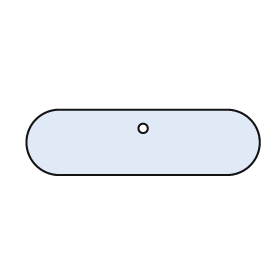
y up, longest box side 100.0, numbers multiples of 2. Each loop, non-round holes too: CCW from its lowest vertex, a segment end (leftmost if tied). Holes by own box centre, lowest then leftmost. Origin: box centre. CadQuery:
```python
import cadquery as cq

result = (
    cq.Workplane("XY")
    .moveTo(-36.0, -14.0)
    .lineTo(36.0, -14.0)
    .threePointArc((50.0, 0.0), (36.0, 14.0))
    .lineTo(-36.0, 14.0)
    .threePointArc((-50.0, 0.0), (-36.0, -14.0))
    .close()
    .moveTo(0.0, 6.0)
    .circle(2.0)
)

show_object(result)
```